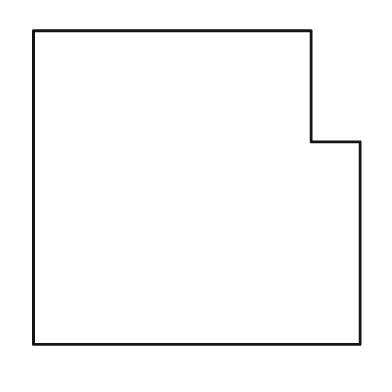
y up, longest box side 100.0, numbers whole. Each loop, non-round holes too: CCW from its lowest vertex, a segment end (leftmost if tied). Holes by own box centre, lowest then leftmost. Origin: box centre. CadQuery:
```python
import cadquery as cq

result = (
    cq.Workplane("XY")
    .moveTo(-50.0, -48.0)
    .lineTo(50.0, -48.0)
    .lineTo(50.0, 14.0)
    .lineTo(35.0, 14.0)
    .lineTo(35.0, 48.0)
    .lineTo(-50.0, 48.0)
    .close()
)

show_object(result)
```